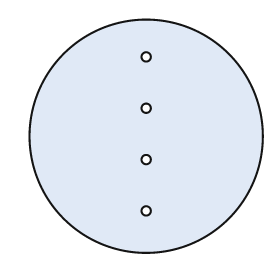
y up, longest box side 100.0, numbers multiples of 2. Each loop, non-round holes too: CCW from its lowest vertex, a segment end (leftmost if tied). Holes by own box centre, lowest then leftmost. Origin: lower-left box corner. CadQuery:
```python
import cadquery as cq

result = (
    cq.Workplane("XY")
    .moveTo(50.0, 50.0)
    .circle(50.0)
    .moveTo(50.0, 18.0)
    .circle(2.0)
    .moveTo(50.0, 40.0)
    .circle(2.0)
    .moveTo(50.0, 62.0)
    .circle(2.0)
    .moveTo(50.0, 84.0)
    .circle(2.0)
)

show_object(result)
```